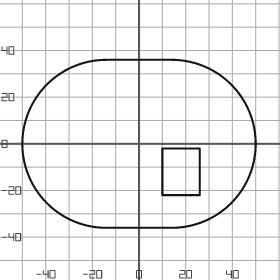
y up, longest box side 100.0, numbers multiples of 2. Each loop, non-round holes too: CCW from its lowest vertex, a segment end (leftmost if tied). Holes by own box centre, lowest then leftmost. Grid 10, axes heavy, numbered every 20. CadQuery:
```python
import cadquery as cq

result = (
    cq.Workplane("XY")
    .moveTo(-14.0, -36.0)
    .lineTo(14.0, -36.0)
    .threePointArc((50.0, 0.0), (14.0, 36.0))
    .lineTo(-14.0, 36.0)
    .threePointArc((-50.0, 0.0), (-14.0, -36.0))
    .close()
    .moveTo(10.0, -22.0)
    .lineTo(26.0, -22.0)
    .lineTo(26.0, -2.0)
    .lineTo(10.0, -2.0)
    .close()
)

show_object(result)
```